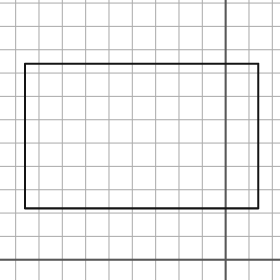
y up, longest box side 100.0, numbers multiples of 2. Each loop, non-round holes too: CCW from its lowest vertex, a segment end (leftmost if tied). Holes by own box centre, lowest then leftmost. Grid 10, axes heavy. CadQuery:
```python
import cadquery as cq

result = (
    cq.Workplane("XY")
    .moveTo(-86.0, 22.0)
    .lineTo(14.0, 22.0)
    .lineTo(14.0, 84.0)
    .lineTo(-86.0, 84.0)
    .close()
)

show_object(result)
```